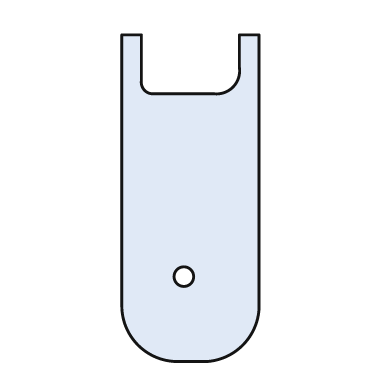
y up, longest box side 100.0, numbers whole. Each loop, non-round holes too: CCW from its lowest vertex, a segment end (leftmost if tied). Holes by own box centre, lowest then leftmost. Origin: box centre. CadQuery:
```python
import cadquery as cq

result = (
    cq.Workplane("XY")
    .moveTo(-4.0, -50.0)
    .lineTo(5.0, -50.0)
    .threePointArc((16.0, -45.0), (21.0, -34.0))
    .lineTo(21.0, 50.0)
    .lineTo(15.0, 50.0)
    .lineTo(15.0, 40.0)
    .threePointArc((13.0, 34.0), (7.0, 32.0))
    .lineTo(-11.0, 32.0)
    .threePointArc((-14.0, 33.0), (-15.0, 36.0))
    .lineTo(-15.0, 50.0)
    .lineTo(-21.0, 50.0)
    .lineTo(-21.0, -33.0)
    .threePointArc((-16.0, -45.0), (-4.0, -50.0))
    .close()
    .moveTo(-2.0, -24.0)
    .circle(3.0)
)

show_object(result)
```